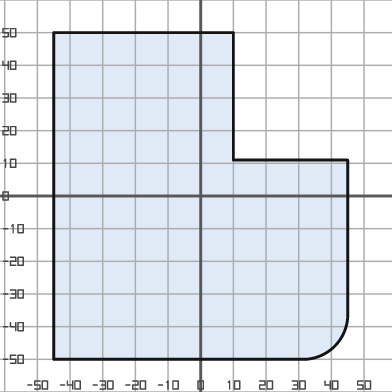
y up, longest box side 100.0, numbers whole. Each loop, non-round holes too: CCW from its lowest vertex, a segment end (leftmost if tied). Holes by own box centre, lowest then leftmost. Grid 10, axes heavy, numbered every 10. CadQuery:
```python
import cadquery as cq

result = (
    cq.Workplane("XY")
    .moveTo(-45.0, -50.0)
    .lineTo(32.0, -50.0)
    .threePointArc((41.0, -46.0), (45.0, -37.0))
    .lineTo(45.0, 11.0)
    .lineTo(10.0, 11.0)
    .lineTo(10.0, 50.0)
    .lineTo(-45.0, 50.0)
    .close()
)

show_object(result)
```